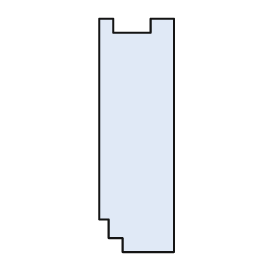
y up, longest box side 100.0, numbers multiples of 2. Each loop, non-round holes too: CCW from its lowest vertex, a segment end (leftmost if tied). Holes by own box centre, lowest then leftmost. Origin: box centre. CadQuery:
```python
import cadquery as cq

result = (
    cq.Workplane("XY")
    .moveTo(-6.0, -50.0)
    .lineTo(16.0, -50.0)
    .lineTo(16.0, 50.0)
    .lineTo(6.0, 50.0)
    .lineTo(6.0, 44.0)
    .lineTo(-10.0, 44.0)
    .lineTo(-10.0, 50.0)
    .lineTo(-16.0, 50.0)
    .lineTo(-16.0, -36.0)
    .lineTo(-12.0, -36.0)
    .lineTo(-12.0, -44.0)
    .lineTo(-6.0, -44.0)
    .close()
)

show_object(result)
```